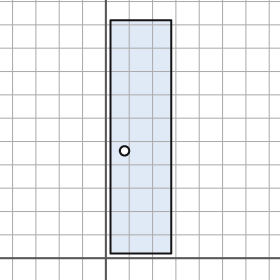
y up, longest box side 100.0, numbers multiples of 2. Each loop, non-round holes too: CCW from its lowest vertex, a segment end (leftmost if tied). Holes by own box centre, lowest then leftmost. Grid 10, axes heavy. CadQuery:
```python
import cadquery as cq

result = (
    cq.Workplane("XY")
    .moveTo(2.0, 2.0)
    .lineTo(28.0, 2.0)
    .lineTo(28.0, 102.0)
    .lineTo(2.0, 102.0)
    .close()
    .moveTo(8.0, 46.0)
    .circle(2.0)
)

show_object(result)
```